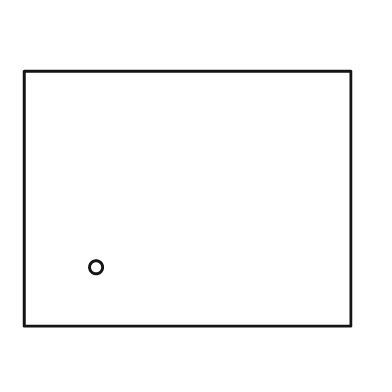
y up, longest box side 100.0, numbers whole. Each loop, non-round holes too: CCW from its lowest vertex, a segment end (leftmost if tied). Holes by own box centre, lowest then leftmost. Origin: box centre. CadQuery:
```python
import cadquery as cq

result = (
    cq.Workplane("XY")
    .moveTo(-50.0, -39.0)
    .lineTo(50.0, -39.0)
    .lineTo(50.0, 39.0)
    .lineTo(-50.0, 39.0)
    .close()
    .moveTo(-28.0, -21.0)
    .circle(2.0)
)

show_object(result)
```